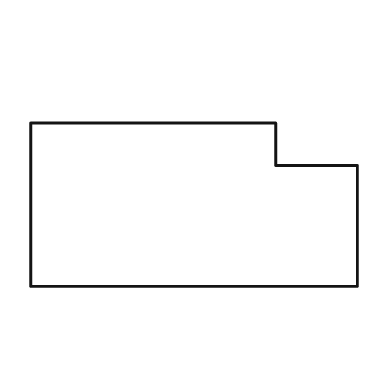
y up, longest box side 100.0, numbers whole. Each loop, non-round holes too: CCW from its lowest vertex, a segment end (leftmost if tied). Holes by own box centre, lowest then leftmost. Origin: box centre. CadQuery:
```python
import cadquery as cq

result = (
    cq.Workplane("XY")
    .moveTo(-50.0, -25.0)
    .lineTo(50.0, -25.0)
    .lineTo(50.0, 12.0)
    .lineTo(25.0, 12.0)
    .lineTo(25.0, 25.0)
    .lineTo(-50.0, 25.0)
    .close()
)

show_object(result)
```